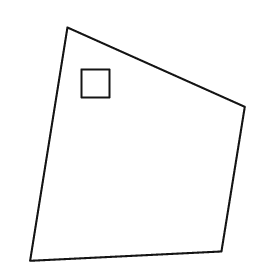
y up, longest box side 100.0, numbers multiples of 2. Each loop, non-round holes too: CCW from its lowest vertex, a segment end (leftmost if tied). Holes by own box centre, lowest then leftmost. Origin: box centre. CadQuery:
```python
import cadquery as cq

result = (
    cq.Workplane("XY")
    .moveTo(-46.0, -50.0)
    .lineTo(36.0, -46.0)
    .lineTo(46.0, 16.0)
    .lineTo(-30.0, 50.0)
    .close()
    .moveTo(-24.0, 20.0)
    .lineTo(-12.0, 20.0)
    .lineTo(-12.0, 32.0)
    .lineTo(-24.0, 32.0)
    .close()
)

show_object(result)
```